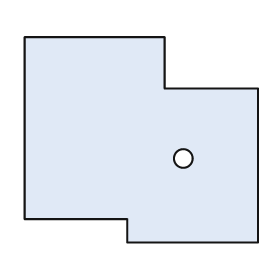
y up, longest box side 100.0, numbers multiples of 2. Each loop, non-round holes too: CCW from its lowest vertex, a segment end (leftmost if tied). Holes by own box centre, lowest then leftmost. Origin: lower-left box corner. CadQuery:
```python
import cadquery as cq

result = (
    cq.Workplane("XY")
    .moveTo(44.0, 0.0)
    .lineTo(100.0, 0.0)
    .lineTo(100.0, 66.0)
    .lineTo(60.0, 66.0)
    .lineTo(60.0, 88.0)
    .lineTo(0.0, 88.0)
    .lineTo(0.0, 10.0)
    .lineTo(44.0, 10.0)
    .close()
    .moveTo(68.0, 36.0)
    .circle(4.0)
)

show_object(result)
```